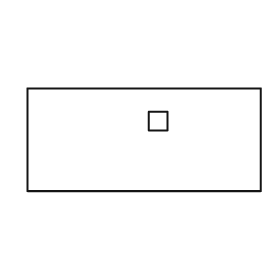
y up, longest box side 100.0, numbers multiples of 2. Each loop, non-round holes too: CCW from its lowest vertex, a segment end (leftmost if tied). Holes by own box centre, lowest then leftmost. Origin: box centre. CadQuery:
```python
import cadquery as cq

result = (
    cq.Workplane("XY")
    .moveTo(-50.0, -22.0)
    .lineTo(50.0, -22.0)
    .lineTo(50.0, 22.0)
    .lineTo(-50.0, 22.0)
    .close()
    .moveTo(2.0, 4.0)
    .lineTo(10.0, 4.0)
    .lineTo(10.0, 12.0)
    .lineTo(2.0, 12.0)
    .close()
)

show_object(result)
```